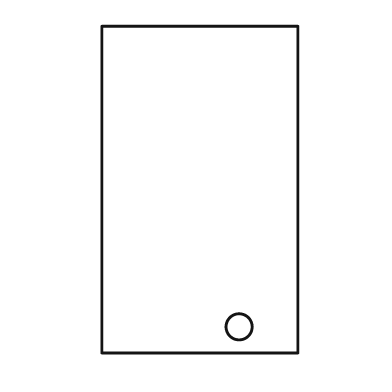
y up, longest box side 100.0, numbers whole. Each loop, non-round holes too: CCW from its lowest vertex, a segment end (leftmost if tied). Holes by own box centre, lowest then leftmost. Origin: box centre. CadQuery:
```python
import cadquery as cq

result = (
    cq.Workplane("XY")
    .moveTo(-30.0, -50.0)
    .lineTo(30.0, -50.0)
    .lineTo(30.0, 50.0)
    .lineTo(-30.0, 50.0)
    .close()
    .moveTo(12.0, -42.0)
    .circle(4.0)
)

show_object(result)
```